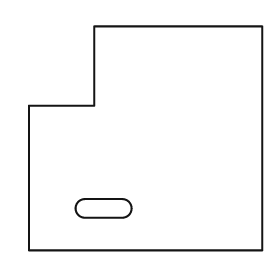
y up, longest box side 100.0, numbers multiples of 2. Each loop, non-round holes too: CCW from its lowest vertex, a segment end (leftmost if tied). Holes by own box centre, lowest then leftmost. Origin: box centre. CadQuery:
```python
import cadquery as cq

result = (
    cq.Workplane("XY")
    .moveTo(-50.0, -48.0)
    .lineTo(50.0, -48.0)
    .lineTo(50.0, 48.0)
    .lineTo(-22.0, 48.0)
    .lineTo(-22.0, 14.0)
    .lineTo(-50.0, 14.0)
    .close()
    .moveTo(-26.0, -34.0)
    .lineTo(-10.0, -34.0)
    .threePointArc((-6.0, -30.0), (-10.0, -26.0))
    .lineTo(-26.0, -26.0)
    .threePointArc((-30.0, -30.0), (-26.0, -34.0))
    .close()
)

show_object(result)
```